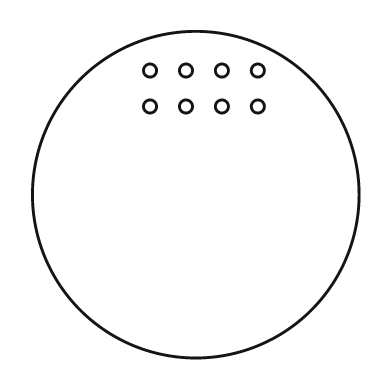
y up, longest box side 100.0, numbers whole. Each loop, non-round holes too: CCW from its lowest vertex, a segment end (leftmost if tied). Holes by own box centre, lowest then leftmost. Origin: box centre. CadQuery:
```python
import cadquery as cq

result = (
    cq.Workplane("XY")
    .moveTo(0.0, 0.0)
    .circle(50.0)
    .moveTo(-14.0, 27.0)
    .circle(2.0)
    .moveTo(-3.0, 27.0)
    .circle(2.0)
    .moveTo(8.0, 27.0)
    .circle(2.0)
    .moveTo(19.0, 27.0)
    .circle(2.0)
    .moveTo(-14.0, 38.0)
    .circle(2.0)
    .moveTo(-3.0, 38.0)
    .circle(2.0)
    .moveTo(8.0, 38.0)
    .circle(2.0)
    .moveTo(19.0, 38.0)
    .circle(2.0)
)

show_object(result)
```